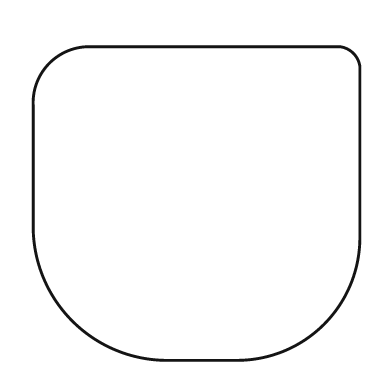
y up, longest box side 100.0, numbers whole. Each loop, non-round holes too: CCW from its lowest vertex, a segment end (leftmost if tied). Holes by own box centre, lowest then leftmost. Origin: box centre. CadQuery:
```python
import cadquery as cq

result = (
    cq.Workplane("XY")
    .moveTo(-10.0, -48.0)
    .lineTo(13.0, -48.0)
    .threePointArc((39.0, -37.0), (50.0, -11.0))
    .lineTo(50.0, 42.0)
    .threePointArc((48.0, 46.0), (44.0, 48.0))
    .lineTo(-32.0, 48.0)
    .threePointArc((-45.0, 43.0), (-50.0, 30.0))
    .lineTo(-50.0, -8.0)
    .threePointArc((-38.0, -36.0), (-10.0, -48.0))
    .close()
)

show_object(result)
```